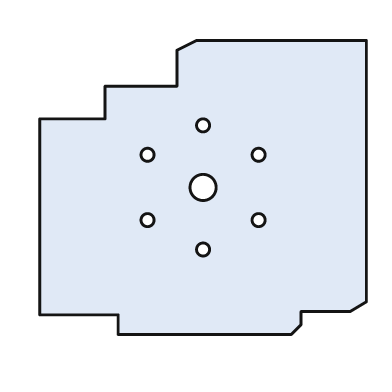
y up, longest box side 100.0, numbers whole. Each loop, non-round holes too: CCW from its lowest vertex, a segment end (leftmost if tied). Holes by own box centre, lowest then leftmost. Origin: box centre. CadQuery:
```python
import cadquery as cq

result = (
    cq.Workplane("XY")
    .moveTo(-26.0, -45.0)
    .lineTo(27.0, -45.0)
    .lineTo(30.0, -42.0)
    .lineTo(30.0, -38.0)
    .lineTo(45.0, -38.0)
    .lineTo(50.0, -35.0)
    .lineTo(50.0, 45.0)
    .lineTo(-2.0, 45.0)
    .lineTo(-8.0, 42.0)
    .lineTo(-8.0, 31.0)
    .lineTo(-30.0, 31.0)
    .lineTo(-30.0, 21.0)
    .lineTo(-50.0, 21.0)
    .lineTo(-50.0, -39.0)
    .lineTo(-26.0, -39.0)
    .close()
    .moveTo(0.0, -19.0)
    .circle(2.0)
    .moveTo(-17.0, -10.0)
    .circle(2.0)
    .moveTo(17.0, -10.0)
    .circle(2.0)
    .moveTo(0.0, 0.0)
    .circle(4.0)
    .moveTo(-17.0, 10.0)
    .circle(2.0)
    .moveTo(17.0, 10.0)
    .circle(2.0)
    .moveTo(0.0, 19.0)
    .circle(2.0)
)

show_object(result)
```